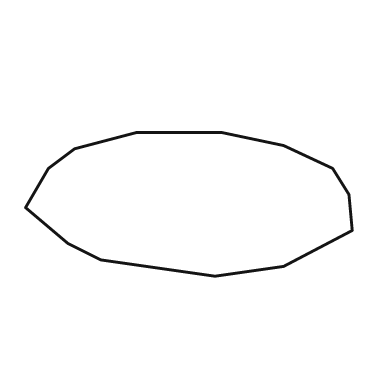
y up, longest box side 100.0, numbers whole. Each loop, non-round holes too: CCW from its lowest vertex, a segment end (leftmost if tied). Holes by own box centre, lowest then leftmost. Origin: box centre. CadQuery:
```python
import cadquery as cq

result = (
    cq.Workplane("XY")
    .moveTo(8.0, -22.0)
    .lineTo(29.0, -19.0)
    .lineTo(50.0, -8.0)
    .lineTo(49.0, 3.0)
    .lineTo(44.0, 11.0)
    .lineTo(29.0, 18.0)
    .lineTo(10.0, 22.0)
    .lineTo(-16.0, 22.0)
    .lineTo(-35.0, 17.0)
    .lineTo(-43.0, 11.0)
    .lineTo(-50.0, -1.0)
    .lineTo(-37.0, -12.0)
    .lineTo(-27.0, -17.0)
    .close()
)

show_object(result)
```